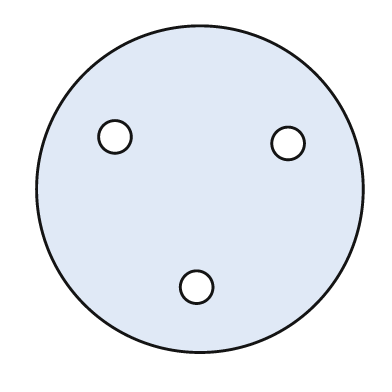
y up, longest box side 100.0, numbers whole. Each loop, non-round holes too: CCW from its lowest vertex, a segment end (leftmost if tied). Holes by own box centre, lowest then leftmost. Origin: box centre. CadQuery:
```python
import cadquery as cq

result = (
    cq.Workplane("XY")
    .moveTo(0.0, 0.0)
    .circle(50.0)
    .moveTo(-1.0, -30.0)
    .circle(5.0)
    .moveTo(27.0, 14.0)
    .circle(5.0)
    .moveTo(-26.0, 16.0)
    .circle(5.0)
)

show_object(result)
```